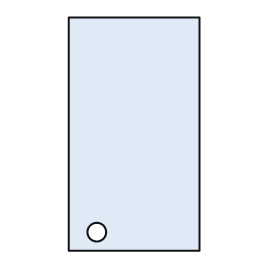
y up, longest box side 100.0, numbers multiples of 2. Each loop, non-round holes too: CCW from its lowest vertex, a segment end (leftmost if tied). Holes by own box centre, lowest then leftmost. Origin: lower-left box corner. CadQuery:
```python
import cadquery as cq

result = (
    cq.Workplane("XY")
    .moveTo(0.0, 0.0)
    .lineTo(56.0, 0.0)
    .lineTo(56.0, 100.0)
    .lineTo(0.0, 100.0)
    .close()
    .moveTo(12.0, 8.0)
    .circle(4.0)
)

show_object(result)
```